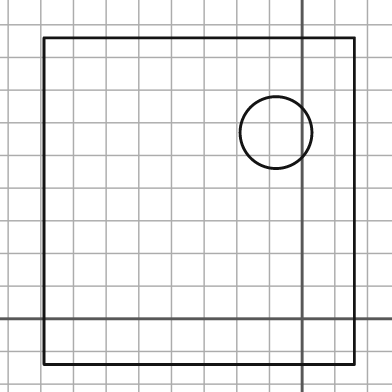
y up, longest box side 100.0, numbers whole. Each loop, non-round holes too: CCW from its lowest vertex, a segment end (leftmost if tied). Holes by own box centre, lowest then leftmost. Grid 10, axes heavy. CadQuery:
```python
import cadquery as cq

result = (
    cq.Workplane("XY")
    .moveTo(-79.0, -14.0)
    .lineTo(16.0, -14.0)
    .lineTo(16.0, 86.0)
    .lineTo(-79.0, 86.0)
    .close()
    .moveTo(-8.0, 57.0)
    .circle(11.0)
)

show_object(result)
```